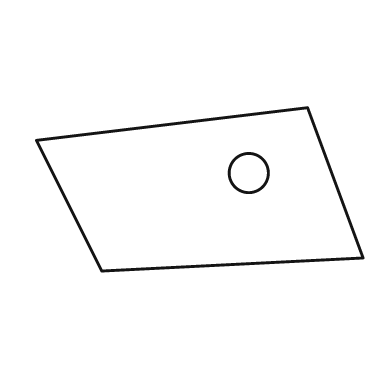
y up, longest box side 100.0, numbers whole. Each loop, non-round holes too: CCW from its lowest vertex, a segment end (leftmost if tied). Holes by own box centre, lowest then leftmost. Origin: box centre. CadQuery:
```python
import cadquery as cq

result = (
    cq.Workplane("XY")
    .moveTo(-30.0, -25.0)
    .lineTo(50.0, -21.0)
    .lineTo(33.0, 25.0)
    .lineTo(-50.0, 15.0)
    .close()
    .moveTo(15.0, 5.0)
    .circle(6.0)
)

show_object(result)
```